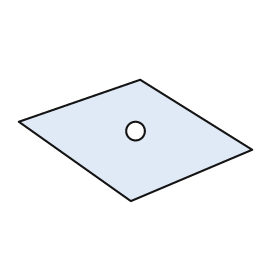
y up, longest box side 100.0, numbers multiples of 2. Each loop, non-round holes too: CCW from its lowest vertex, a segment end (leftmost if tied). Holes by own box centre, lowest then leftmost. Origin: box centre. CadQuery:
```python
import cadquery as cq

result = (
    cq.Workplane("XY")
    .moveTo(-2.0, -26.0)
    .lineTo(50.0, -4.0)
    .lineTo(2.0, 26.0)
    .lineTo(-50.0, 8.0)
    .close()
    .moveTo(0.0, 4.0)
    .circle(4.0)
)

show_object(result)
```